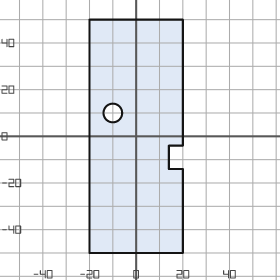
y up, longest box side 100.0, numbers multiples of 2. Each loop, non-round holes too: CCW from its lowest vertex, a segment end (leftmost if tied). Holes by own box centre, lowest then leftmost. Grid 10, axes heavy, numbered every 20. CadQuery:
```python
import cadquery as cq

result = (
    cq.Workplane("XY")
    .moveTo(-20.0, -50.0)
    .lineTo(20.0, -50.0)
    .lineTo(20.0, -14.0)
    .lineTo(14.0, -14.0)
    .lineTo(14.0, -4.0)
    .lineTo(20.0, -4.0)
    .lineTo(20.0, 50.0)
    .lineTo(-20.0, 50.0)
    .close()
    .moveTo(-10.0, 10.0)
    .circle(4.0)
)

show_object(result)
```